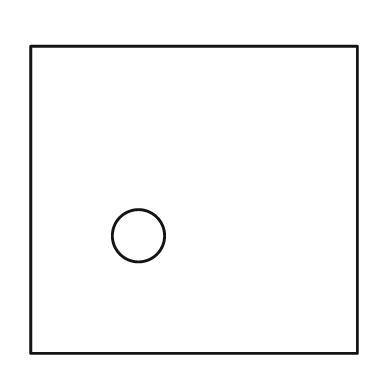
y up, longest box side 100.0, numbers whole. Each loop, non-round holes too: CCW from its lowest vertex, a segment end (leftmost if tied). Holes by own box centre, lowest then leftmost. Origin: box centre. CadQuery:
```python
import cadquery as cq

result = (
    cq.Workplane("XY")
    .moveTo(-50.0, -47.0)
    .lineTo(50.0, -47.0)
    .lineTo(50.0, 47.0)
    .lineTo(-50.0, 47.0)
    .close()
    .moveTo(-17.0, -11.0)
    .circle(8.0)
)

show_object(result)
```